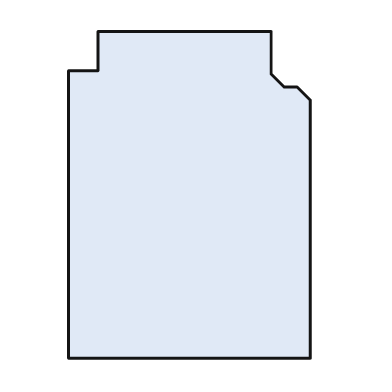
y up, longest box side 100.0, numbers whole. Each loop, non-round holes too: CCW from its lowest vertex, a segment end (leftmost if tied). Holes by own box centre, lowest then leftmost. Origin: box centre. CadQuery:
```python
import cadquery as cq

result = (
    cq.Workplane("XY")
    .moveTo(-37.0, -50.0)
    .lineTo(37.0, -50.0)
    .lineTo(37.0, 29.0)
    .lineTo(33.0, 33.0)
    .lineTo(29.0, 33.0)
    .lineTo(25.0, 37.0)
    .lineTo(25.0, 50.0)
    .lineTo(-28.0, 50.0)
    .lineTo(-28.0, 38.0)
    .lineTo(-37.0, 38.0)
    .close()
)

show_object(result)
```